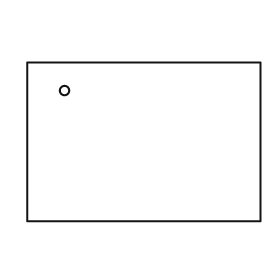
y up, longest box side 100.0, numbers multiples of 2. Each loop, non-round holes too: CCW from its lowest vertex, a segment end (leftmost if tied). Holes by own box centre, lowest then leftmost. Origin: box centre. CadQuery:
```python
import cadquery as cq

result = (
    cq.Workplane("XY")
    .moveTo(-50.0, -34.0)
    .lineTo(50.0, -34.0)
    .lineTo(50.0, 34.0)
    .lineTo(-50.0, 34.0)
    .close()
    .moveTo(-34.0, 22.0)
    .circle(2.0)
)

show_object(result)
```